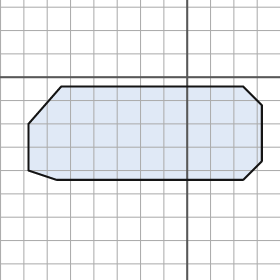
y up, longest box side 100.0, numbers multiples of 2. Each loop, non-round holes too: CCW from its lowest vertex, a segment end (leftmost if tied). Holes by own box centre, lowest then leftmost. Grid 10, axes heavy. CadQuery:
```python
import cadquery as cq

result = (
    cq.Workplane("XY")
    .moveTo(-56.0, -44.0)
    .lineTo(24.0, -44.0)
    .lineTo(32.0, -36.0)
    .lineTo(32.0, -12.0)
    .lineTo(24.0, -4.0)
    .lineTo(-54.0, -4.0)
    .lineTo(-68.0, -20.0)
    .lineTo(-68.0, -40.0)
    .close()
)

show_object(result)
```